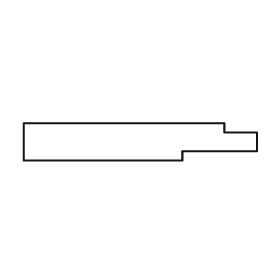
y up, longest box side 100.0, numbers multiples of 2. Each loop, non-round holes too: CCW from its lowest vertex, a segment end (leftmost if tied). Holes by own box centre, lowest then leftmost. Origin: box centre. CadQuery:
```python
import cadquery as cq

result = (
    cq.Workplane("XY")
    .moveTo(-50.0, -8.0)
    .lineTo(18.0, -8.0)
    .lineTo(18.0, -4.0)
    .lineTo(50.0, -4.0)
    .lineTo(50.0, 4.0)
    .lineTo(36.0, 4.0)
    .lineTo(36.0, 8.0)
    .lineTo(-50.0, 8.0)
    .close()
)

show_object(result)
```